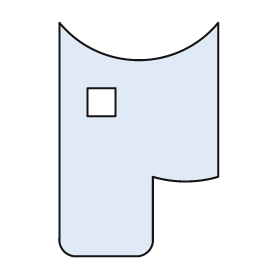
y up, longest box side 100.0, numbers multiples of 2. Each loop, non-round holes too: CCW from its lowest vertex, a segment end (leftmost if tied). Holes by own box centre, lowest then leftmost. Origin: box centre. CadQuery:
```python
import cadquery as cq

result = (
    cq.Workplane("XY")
    .moveTo(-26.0, -50.0)
    .lineTo(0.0, -50.0)
    .threePointArc((4.0, -48.0), (6.0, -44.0))
    .lineTo(6.0, -16.0)
    .threePointArc((20.0, -18.0), (34.0, -16.0))
    .lineTo(34.0, 50.0)
    .threePointArc((0.0, 34.0), (-34.0, 50.0))
    .lineTo(-34.0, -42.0)
    .threePointArc((-32.0, -48.0), (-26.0, -50.0))
    .close()
    .moveTo(-22.0, 10.0)
    .lineTo(-10.0, 10.0)
    .lineTo(-10.0, 22.0)
    .lineTo(-22.0, 22.0)
    .close()
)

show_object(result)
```